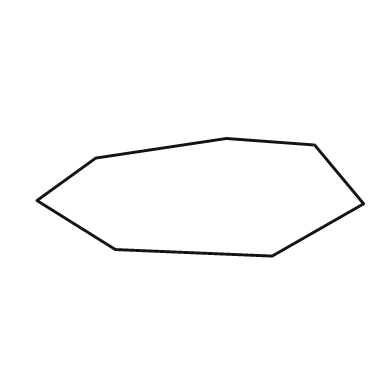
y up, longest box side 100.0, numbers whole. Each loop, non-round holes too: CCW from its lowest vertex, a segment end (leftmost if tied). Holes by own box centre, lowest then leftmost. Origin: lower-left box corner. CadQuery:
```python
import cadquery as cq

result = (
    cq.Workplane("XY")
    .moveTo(72.0, 0.0)
    .lineTo(100.0, 16.0)
    .lineTo(85.0, 34.0)
    .lineTo(58.0, 36.0)
    .lineTo(18.0, 30.0)
    .lineTo(0.0, 17.0)
    .lineTo(24.0, 2.0)
    .close()
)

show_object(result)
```